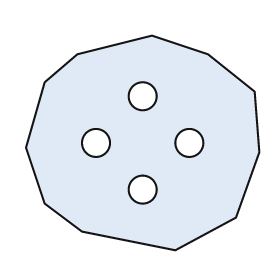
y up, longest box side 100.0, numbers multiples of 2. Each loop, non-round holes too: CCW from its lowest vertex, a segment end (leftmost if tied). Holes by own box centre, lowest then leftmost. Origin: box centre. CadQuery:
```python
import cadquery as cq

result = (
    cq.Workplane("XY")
    .moveTo(14.0, -46.0)
    .lineTo(40.0, -32.0)
    .lineTo(50.0, -4.0)
    .lineTo(48.0, 22.0)
    .lineTo(28.0, 38.0)
    .lineTo(4.0, 46.0)
    .lineTo(-28.0, 38.0)
    .lineTo(-42.0, 26.0)
    .lineTo(-50.0, -2.0)
    .lineTo(-42.0, -26.0)
    .lineTo(-26.0, -38.0)
    .close()
    .moveTo(0.0, -20.0)
    .circle(6.0)
    .moveTo(-20.0, 0.0)
    .circle(6.0)
    .moveTo(20.0, 0.0)
    .circle(6.0)
    .moveTo(0.0, 20.0)
    .circle(6.0)
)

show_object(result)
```